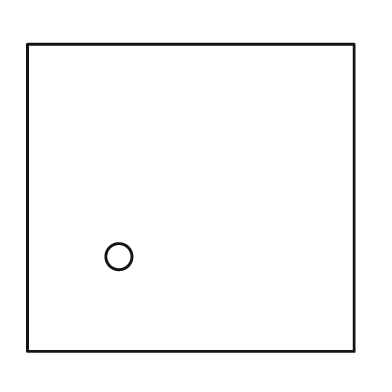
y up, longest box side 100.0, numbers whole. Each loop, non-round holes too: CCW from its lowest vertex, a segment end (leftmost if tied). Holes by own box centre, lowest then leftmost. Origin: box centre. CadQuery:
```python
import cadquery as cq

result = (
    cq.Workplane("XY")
    .moveTo(-50.0, -47.0)
    .lineTo(50.0, -47.0)
    .lineTo(50.0, 47.0)
    .lineTo(-50.0, 47.0)
    .close()
    .moveTo(-22.0, -18.0)
    .circle(4.0)
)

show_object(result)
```